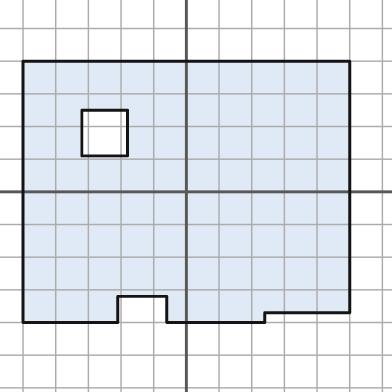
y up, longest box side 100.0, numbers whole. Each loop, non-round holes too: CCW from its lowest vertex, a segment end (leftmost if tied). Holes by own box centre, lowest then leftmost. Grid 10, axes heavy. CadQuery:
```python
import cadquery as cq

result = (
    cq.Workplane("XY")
    .moveTo(-50.0, -40.0)
    .lineTo(-21.0, -40.0)
    .lineTo(-21.0, -32.0)
    .lineTo(-6.0, -32.0)
    .lineTo(-6.0, -40.0)
    .lineTo(24.0, -40.0)
    .lineTo(24.0, -37.0)
    .lineTo(50.0, -37.0)
    .lineTo(50.0, 40.0)
    .lineTo(-50.0, 40.0)
    .close()
    .moveTo(-32.0, 11.0)
    .lineTo(-18.0, 11.0)
    .lineTo(-18.0, 25.0)
    .lineTo(-32.0, 25.0)
    .close()
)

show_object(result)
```